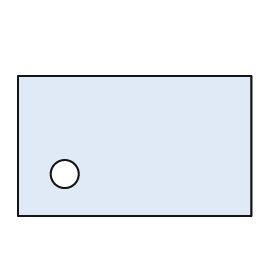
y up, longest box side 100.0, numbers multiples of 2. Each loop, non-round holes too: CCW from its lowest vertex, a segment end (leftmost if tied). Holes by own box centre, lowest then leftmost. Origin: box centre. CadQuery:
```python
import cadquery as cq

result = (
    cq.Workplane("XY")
    .moveTo(-50.0, -30.0)
    .lineTo(50.0, -30.0)
    .lineTo(50.0, 30.0)
    .lineTo(-50.0, 30.0)
    .close()
    .moveTo(-30.0, -12.0)
    .circle(6.0)
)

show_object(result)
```